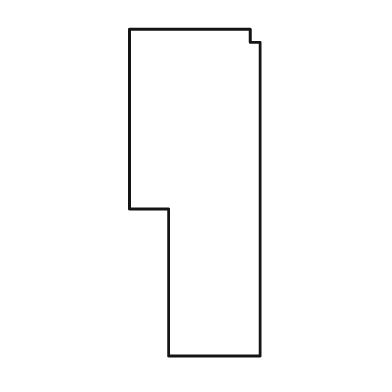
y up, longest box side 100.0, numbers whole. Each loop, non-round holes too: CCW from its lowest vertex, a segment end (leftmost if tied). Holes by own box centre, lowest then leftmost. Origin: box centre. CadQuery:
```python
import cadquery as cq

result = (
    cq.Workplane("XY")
    .moveTo(-8.0, -50.0)
    .lineTo(20.0, -50.0)
    .lineTo(20.0, 46.0)
    .lineTo(17.0, 46.0)
    .lineTo(17.0, 50.0)
    .lineTo(-20.0, 50.0)
    .lineTo(-20.0, -5.0)
    .lineTo(-8.0, -5.0)
    .close()
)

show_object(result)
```